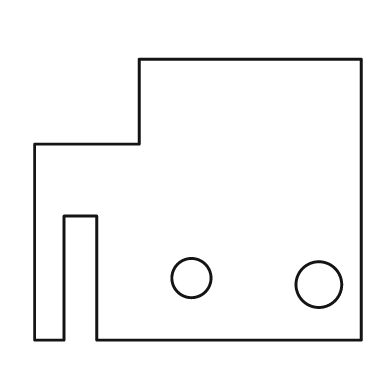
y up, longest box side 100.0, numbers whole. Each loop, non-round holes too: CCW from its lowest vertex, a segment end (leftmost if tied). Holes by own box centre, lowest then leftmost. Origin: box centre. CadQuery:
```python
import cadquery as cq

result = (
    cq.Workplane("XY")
    .moveTo(-50.0, -43.0)
    .lineTo(-41.0, -43.0)
    .lineTo(-41.0, -5.0)
    .lineTo(-31.0, -5.0)
    .lineTo(-31.0, -43.0)
    .lineTo(50.0, -43.0)
    .lineTo(50.0, 43.0)
    .lineTo(-18.0, 43.0)
    .lineTo(-18.0, 17.0)
    .lineTo(-50.0, 17.0)
    .close()
    .moveTo(37.0, -26.0)
    .circle(7.0)
    .moveTo(-2.0, -24.0)
    .circle(6.0)
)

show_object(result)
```